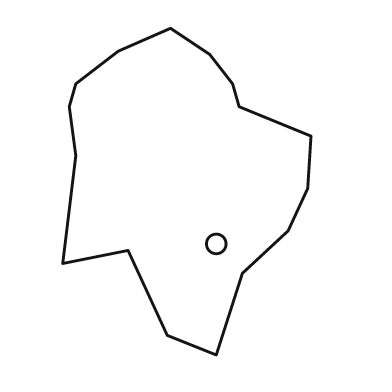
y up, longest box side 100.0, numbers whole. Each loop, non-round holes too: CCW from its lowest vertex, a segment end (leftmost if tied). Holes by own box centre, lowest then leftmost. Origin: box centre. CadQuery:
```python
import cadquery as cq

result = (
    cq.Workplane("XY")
    .moveTo(9.0, -50.0)
    .lineTo(17.0, -25.0)
    .lineTo(31.0, -12.0)
    .lineTo(37.0, 1.0)
    .lineTo(38.0, 17.0)
    .lineTo(16.0, 26.0)
    .lineTo(14.0, 33.0)
    .lineTo(7.0, 42.0)
    .lineTo(-5.0, 50.0)
    .lineTo(-21.0, 43.0)
    .lineTo(-34.0, 33.0)
    .lineTo(-36.0, 26.0)
    .lineTo(-34.0, 11.0)
    .lineTo(-38.0, -22.0)
    .lineTo(-18.0, -18.0)
    .lineTo(-6.0, -44.0)
    .close()
    .moveTo(9.0, -16.0)
    .circle(3.0)
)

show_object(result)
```